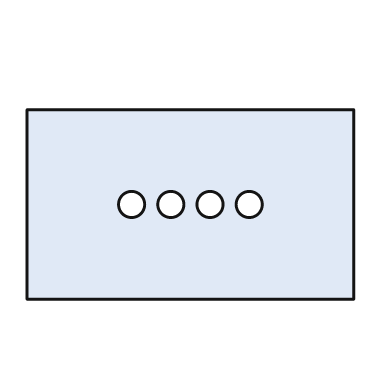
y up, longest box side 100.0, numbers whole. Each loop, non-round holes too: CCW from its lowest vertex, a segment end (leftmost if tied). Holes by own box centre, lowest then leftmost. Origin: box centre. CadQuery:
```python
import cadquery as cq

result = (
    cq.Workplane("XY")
    .moveTo(-50.0, -29.0)
    .lineTo(50.0, -29.0)
    .lineTo(50.0, 29.0)
    .lineTo(-50.0, 29.0)
    .close()
    .moveTo(-18.0, 0.0)
    .circle(4.0)
    .moveTo(-6.0, 0.0)
    .circle(4.0)
    .moveTo(6.0, 0.0)
    .circle(4.0)
    .moveTo(18.0, 0.0)
    .circle(4.0)
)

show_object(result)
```